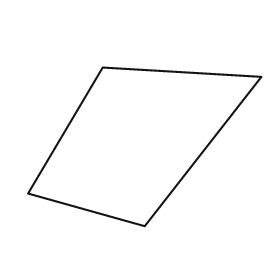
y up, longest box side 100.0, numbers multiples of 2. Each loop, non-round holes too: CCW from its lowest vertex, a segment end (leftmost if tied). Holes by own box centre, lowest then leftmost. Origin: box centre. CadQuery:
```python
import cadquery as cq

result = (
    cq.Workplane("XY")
    .moveTo(0.0, -34.0)
    .lineTo(50.0, 30.0)
    .lineTo(-18.0, 34.0)
    .lineTo(-50.0, -20.0)
    .close()
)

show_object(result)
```